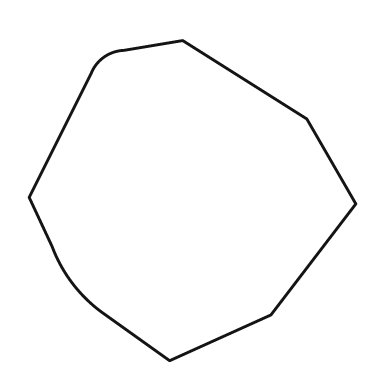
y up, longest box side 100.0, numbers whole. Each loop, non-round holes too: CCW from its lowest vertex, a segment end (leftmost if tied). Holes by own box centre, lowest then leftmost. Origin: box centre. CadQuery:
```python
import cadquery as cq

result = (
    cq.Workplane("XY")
    .moveTo(-7.0, -49.0)
    .lineTo(24.0, -35.0)
    .lineTo(50.0, -1.0)
    .lineTo(35.0, 25.0)
    .lineTo(-3.0, 49.0)
    .lineTo(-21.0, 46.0)
    .threePointArc((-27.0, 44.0), (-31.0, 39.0))
    .lineTo(-50.0, 1.0)
    .lineTo(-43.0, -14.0)
    .threePointArc((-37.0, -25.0), (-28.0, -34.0))
    .close()
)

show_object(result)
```